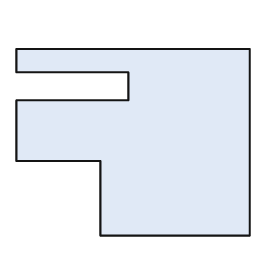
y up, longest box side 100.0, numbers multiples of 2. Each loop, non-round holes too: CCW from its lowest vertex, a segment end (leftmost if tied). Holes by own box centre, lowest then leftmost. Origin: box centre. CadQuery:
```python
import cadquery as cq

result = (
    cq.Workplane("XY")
    .moveTo(-14.0, -40.0)
    .lineTo(50.0, -40.0)
    .lineTo(50.0, 40.0)
    .lineTo(-50.0, 40.0)
    .lineTo(-50.0, 30.0)
    .lineTo(-2.0, 30.0)
    .lineTo(-2.0, 18.0)
    .lineTo(-50.0, 18.0)
    .lineTo(-50.0, -8.0)
    .lineTo(-14.0, -8.0)
    .close()
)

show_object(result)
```